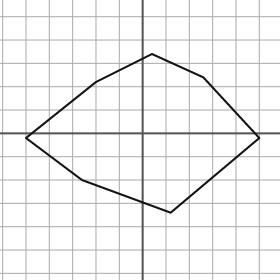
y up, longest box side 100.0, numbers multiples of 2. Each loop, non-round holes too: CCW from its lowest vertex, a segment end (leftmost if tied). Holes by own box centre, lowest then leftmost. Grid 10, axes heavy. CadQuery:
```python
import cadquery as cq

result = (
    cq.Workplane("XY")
    .moveTo(12.0, -34.0)
    .lineTo(50.0, -2.0)
    .lineTo(26.0, 24.0)
    .lineTo(4.0, 34.0)
    .lineTo(-20.0, 22.0)
    .lineTo(-50.0, -2.0)
    .lineTo(-26.0, -20.0)
    .close()
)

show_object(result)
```